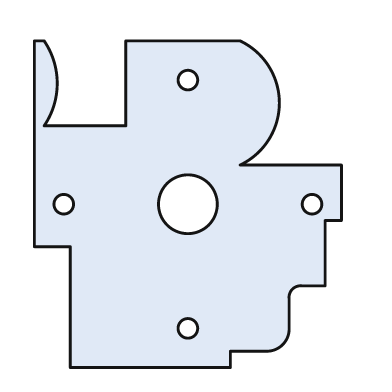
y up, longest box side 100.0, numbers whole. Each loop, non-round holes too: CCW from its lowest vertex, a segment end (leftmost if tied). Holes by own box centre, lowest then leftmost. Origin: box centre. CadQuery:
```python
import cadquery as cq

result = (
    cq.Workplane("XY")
    .moveTo(-36.0, -50.0)
    .lineTo(13.0, -50.0)
    .lineTo(13.0, -45.0)
    .lineTo(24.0, -45.0)
    .threePointArc((29.0, -43.0), (31.0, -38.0))
    .lineTo(31.0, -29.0)
    .threePointArc((32.0, -26.0), (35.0, -25.0))
    .lineTo(42.0, -25.0)
    .lineTo(42.0, -5.0)
    .lineTo(47.0, -5.0)
    .lineTo(47.0, 12.0)
    .lineTo(16.0, 12.0)
    .threePointArc((28.0, 31.0), (16.0, 50.0))
    .lineTo(-19.0, 50.0)
    .lineTo(-19.0, 24.0)
    .lineTo(-44.0, 24.0)
    .threePointArc((-40.0, 37.0), (-44.0, 50.0))
    .lineTo(-47.0, 50.0)
    .lineTo(-47.0, -13.0)
    .lineTo(-36.0, -13.0)
    .close()
    .moveTo(0.0, -38.0)
    .circle(3.0)
    .moveTo(-38.0, 0.0)
    .circle(3.0)
    .moveTo(0.0, 0.0)
    .circle(9.0)
    .moveTo(38.0, 0.0)
    .circle(3.0)
    .moveTo(0.0, 38.0)
    .circle(3.0)
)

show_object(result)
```